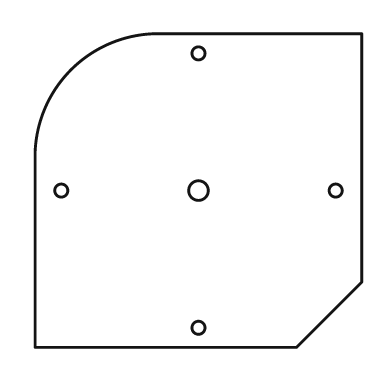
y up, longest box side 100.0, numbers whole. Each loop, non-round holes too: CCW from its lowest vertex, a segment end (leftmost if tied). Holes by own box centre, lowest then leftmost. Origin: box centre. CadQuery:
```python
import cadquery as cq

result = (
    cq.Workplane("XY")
    .moveTo(-50.0, -48.0)
    .lineTo(30.0, -48.0)
    .lineTo(50.0, -28.0)
    .lineTo(50.0, 48.0)
    .lineTo(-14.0, 48.0)
    .threePointArc((-39.0, 37.0), (-50.0, 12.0))
    .close()
    .moveTo(0.0, -42.0)
    .circle(2.0)
    .moveTo(-42.0, 0.0)
    .circle(2.0)
    .moveTo(0.0, 0.0)
    .circle(3.0)
    .moveTo(42.0, 0.0)
    .circle(2.0)
    .moveTo(0.0, 42.0)
    .circle(2.0)
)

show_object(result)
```